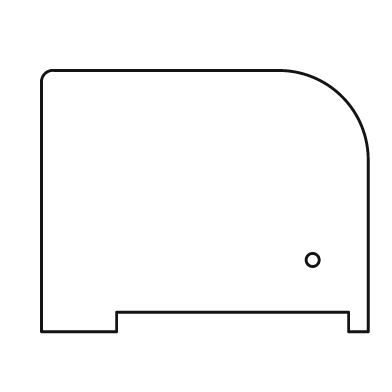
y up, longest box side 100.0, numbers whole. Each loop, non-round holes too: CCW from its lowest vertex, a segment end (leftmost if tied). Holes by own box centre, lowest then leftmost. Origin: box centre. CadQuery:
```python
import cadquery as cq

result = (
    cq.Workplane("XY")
    .moveTo(-50.0, -40.0)
    .lineTo(-27.0, -40.0)
    .lineTo(-27.0, -34.0)
    .lineTo(44.0, -34.0)
    .lineTo(44.0, -40.0)
    .lineTo(50.0, -40.0)
    .lineTo(50.0, 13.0)
    .threePointArc((42.0, 32.0), (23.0, 40.0))
    .lineTo(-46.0, 40.0)
    .threePointArc((-49.0, 39.0), (-50.0, 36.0))
    .close()
    .moveTo(33.0, -18.0)
    .circle(2.0)
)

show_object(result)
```